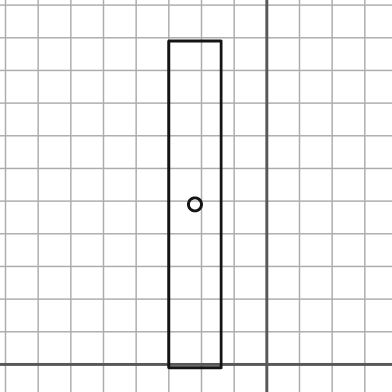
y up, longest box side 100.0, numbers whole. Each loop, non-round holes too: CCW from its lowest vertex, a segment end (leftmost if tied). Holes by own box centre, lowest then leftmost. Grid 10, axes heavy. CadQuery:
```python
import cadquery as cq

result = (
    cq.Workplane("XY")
    .moveTo(-30.0, -1.0)
    .lineTo(-14.0, -1.0)
    .lineTo(-14.0, 99.0)
    .lineTo(-30.0, 99.0)
    .close()
    .moveTo(-22.0, 49.0)
    .circle(2.0)
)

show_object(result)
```